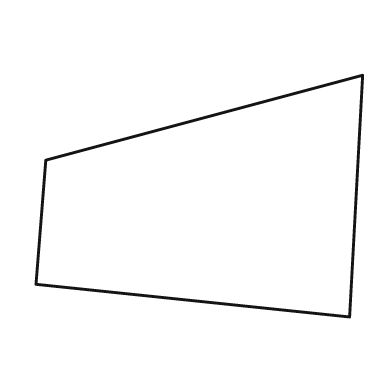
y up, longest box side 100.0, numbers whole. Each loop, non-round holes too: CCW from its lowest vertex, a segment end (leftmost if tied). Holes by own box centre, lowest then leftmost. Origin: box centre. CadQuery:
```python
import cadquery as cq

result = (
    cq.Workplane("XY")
    .moveTo(46.0, -37.0)
    .lineTo(50.0, 37.0)
    .lineTo(-47.0, 11.0)
    .lineTo(-50.0, -27.0)
    .close()
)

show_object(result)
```